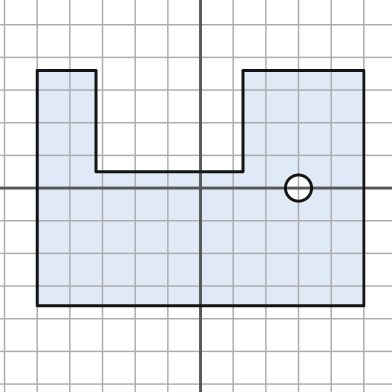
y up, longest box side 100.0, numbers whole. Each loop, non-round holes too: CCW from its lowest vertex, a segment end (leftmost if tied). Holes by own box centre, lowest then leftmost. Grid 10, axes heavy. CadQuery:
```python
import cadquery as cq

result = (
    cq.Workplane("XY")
    .moveTo(-50.0, -36.0)
    .lineTo(50.0, -36.0)
    .lineTo(50.0, 36.0)
    .lineTo(13.0, 36.0)
    .lineTo(13.0, 5.0)
    .lineTo(-32.0, 5.0)
    .lineTo(-32.0, 36.0)
    .lineTo(-50.0, 36.0)
    .close()
    .moveTo(30.0, 0.0)
    .circle(4.0)
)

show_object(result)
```